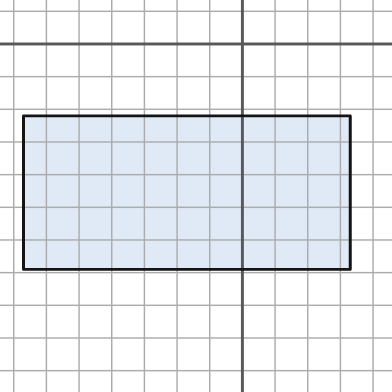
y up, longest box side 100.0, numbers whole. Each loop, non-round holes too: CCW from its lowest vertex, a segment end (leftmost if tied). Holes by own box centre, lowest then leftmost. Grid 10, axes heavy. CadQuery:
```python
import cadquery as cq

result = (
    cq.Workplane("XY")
    .moveTo(-67.0, -69.0)
    .lineTo(33.0, -69.0)
    .lineTo(33.0, -22.0)
    .lineTo(-67.0, -22.0)
    .close()
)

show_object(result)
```